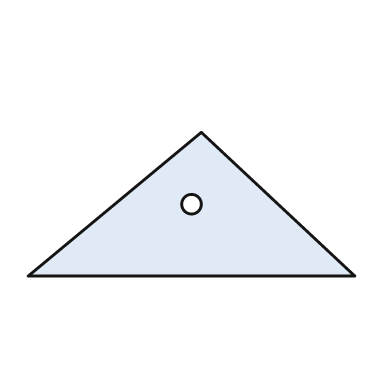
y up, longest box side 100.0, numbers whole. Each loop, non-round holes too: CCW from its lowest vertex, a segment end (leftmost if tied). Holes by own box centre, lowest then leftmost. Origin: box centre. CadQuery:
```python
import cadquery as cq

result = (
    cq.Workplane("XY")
    .moveTo(-50.0, -22.0)
    .lineTo(50.0, -22.0)
    .lineTo(3.0, 22.0)
    .close()
    .moveTo(0.0, 0.0)
    .circle(3.0)
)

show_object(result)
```